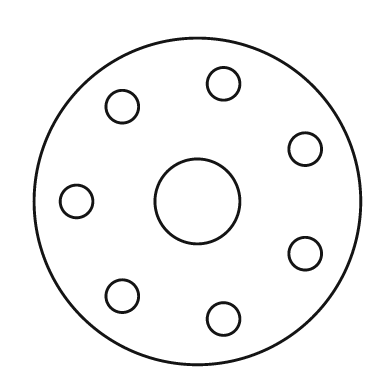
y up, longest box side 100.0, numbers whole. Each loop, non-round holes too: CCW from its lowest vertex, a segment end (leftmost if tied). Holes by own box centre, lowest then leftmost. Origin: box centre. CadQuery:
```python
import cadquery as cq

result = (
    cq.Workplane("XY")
    .moveTo(0.0, 0.0)
    .circle(50.0)
    .moveTo(8.0, -36.0)
    .circle(5.0)
    .moveTo(-23.0, -29.0)
    .circle(5.0)
    .moveTo(33.0, -16.0)
    .circle(5.0)
    .moveTo(-37.0, 0.0)
    .circle(5.0)
    .moveTo(0.0, 0.0)
    .circle(13.0)
    .moveTo(33.0, 16.0)
    .circle(5.0)
    .moveTo(-23.0, 29.0)
    .circle(5.0)
    .moveTo(8.0, 36.0)
    .circle(5.0)
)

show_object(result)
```